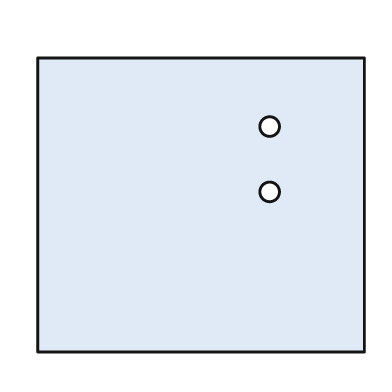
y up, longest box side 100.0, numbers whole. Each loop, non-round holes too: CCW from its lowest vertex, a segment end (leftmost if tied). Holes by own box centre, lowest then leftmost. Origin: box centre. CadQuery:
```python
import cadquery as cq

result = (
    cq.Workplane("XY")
    .moveTo(-50.0, -45.0)
    .lineTo(50.0, -45.0)
    .lineTo(50.0, 45.0)
    .lineTo(-50.0, 45.0)
    .close()
    .moveTo(21.0, 4.0)
    .circle(3.0)
    .moveTo(21.0, 24.0)
    .circle(3.0)
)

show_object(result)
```